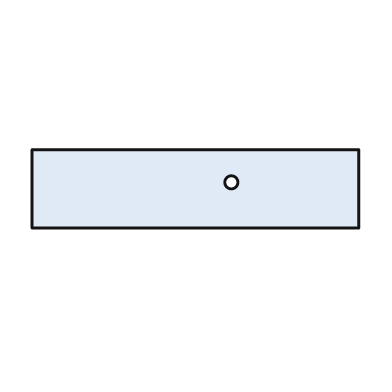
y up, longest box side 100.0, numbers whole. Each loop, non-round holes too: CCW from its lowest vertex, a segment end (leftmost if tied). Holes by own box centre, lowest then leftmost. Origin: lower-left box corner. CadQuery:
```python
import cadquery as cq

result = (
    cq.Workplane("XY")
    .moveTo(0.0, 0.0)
    .lineTo(100.0, 0.0)
    .lineTo(100.0, 24.0)
    .lineTo(0.0, 24.0)
    .close()
    .moveTo(61.0, 14.0)
    .circle(2.0)
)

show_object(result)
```